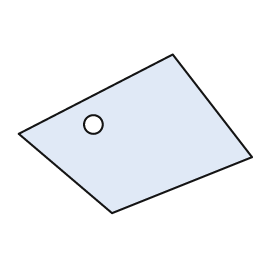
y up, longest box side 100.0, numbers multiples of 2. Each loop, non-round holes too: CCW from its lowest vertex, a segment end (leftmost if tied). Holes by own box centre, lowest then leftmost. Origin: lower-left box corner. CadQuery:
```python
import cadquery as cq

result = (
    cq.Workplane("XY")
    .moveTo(40.0, 0.0)
    .lineTo(100.0, 24.0)
    .lineTo(66.0, 68.0)
    .lineTo(0.0, 34.0)
    .close()
    .moveTo(32.0, 38.0)
    .circle(4.0)
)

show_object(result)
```